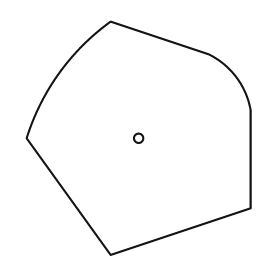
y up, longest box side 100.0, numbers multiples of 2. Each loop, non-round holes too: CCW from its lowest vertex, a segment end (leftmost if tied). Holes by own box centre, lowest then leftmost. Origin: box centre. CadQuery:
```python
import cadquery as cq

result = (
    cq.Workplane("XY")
    .moveTo(-12.0, -50.0)
    .lineTo(48.0, -30.0)
    .lineTo(48.0, 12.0)
    .threePointArc((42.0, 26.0), (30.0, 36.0))
    .lineTo(-12.0, 50.0)
    .threePointArc((-34.0, 28.0), (-48.0, 0.0))
    .close()
    .moveTo(0.0, 0.0)
    .circle(2.0)
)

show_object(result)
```